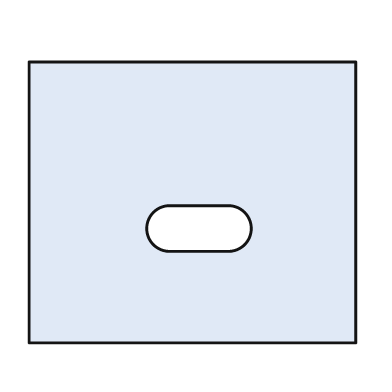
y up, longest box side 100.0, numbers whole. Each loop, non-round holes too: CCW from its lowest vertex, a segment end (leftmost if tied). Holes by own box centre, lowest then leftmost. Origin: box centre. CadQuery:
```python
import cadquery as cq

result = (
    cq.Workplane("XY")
    .moveTo(-50.0, -43.0)
    .lineTo(50.0, -43.0)
    .lineTo(50.0, 43.0)
    .lineTo(-50.0, 43.0)
    .close()
    .moveTo(-7.0, -15.0)
    .lineTo(11.0, -15.0)
    .threePointArc((18.0, -8.0), (11.0, -1.0))
    .lineTo(-7.0, -1.0)
    .threePointArc((-14.0, -8.0), (-7.0, -15.0))
    .close()
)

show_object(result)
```